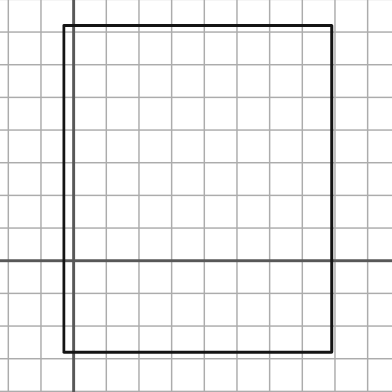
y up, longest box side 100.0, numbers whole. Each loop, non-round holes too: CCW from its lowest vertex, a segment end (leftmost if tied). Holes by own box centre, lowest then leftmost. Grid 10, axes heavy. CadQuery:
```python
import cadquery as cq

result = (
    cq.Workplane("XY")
    .moveTo(-3.0, -28.0)
    .lineTo(79.0, -28.0)
    .lineTo(79.0, 72.0)
    .lineTo(-3.0, 72.0)
    .close()
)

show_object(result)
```